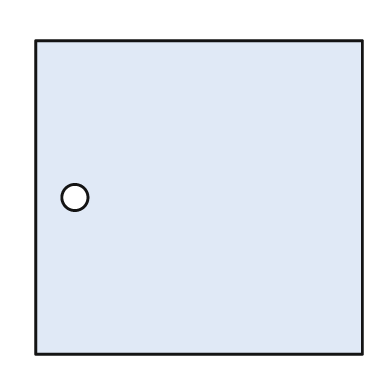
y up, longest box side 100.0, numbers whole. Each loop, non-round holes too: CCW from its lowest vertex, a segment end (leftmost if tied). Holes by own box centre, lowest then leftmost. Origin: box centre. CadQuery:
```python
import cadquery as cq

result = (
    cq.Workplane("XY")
    .moveTo(-50.0, -48.0)
    .lineTo(50.0, -48.0)
    .lineTo(50.0, 48.0)
    .lineTo(-50.0, 48.0)
    .close()
    .moveTo(-38.0, 0.0)
    .circle(4.0)
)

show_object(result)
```